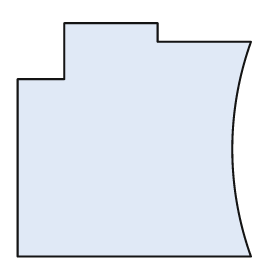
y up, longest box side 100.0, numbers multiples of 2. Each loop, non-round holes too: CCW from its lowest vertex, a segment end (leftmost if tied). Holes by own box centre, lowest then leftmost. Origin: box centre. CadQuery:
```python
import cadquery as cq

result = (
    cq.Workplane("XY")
    .moveTo(-50.0, -50.0)
    .lineTo(50.0, -50.0)
    .threePointArc((42.0, -4.0), (50.0, 42.0))
    .lineTo(10.0, 42.0)
    .lineTo(10.0, 50.0)
    .lineTo(-30.0, 50.0)
    .lineTo(-30.0, 26.0)
    .lineTo(-50.0, 26.0)
    .close()
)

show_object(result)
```